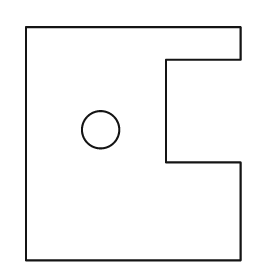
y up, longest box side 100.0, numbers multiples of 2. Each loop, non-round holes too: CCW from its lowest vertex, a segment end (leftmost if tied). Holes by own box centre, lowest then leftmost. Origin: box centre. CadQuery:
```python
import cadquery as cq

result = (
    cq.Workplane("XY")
    .moveTo(-46.0, -50.0)
    .lineTo(46.0, -50.0)
    .lineTo(46.0, -8.0)
    .lineTo(14.0, -8.0)
    .lineTo(14.0, 36.0)
    .lineTo(46.0, 36.0)
    .lineTo(46.0, 50.0)
    .lineTo(-46.0, 50.0)
    .close()
    .moveTo(-14.0, 6.0)
    .circle(8.0)
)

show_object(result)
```